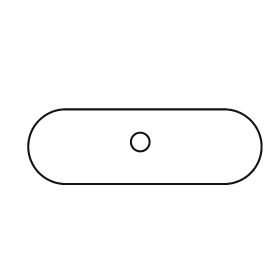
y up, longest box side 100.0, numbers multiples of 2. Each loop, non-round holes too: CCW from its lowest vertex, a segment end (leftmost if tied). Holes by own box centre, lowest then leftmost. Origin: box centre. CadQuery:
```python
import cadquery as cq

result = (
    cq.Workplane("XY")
    .moveTo(-34.0, -16.0)
    .lineTo(34.0, -16.0)
    .threePointArc((50.0, 0.0), (34.0, 16.0))
    .lineTo(-34.0, 16.0)
    .threePointArc((-50.0, 0.0), (-34.0, -16.0))
    .close()
    .moveTo(-2.0, 2.0)
    .circle(4.0)
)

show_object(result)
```